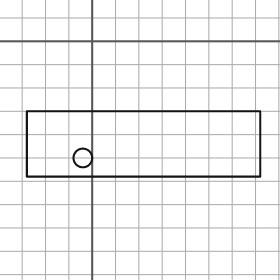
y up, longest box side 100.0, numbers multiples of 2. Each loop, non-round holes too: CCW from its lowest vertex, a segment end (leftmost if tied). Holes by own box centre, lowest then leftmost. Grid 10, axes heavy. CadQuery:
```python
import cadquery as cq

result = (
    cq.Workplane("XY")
    .moveTo(-28.0, -58.0)
    .lineTo(72.0, -58.0)
    .lineTo(72.0, -30.0)
    .lineTo(-28.0, -30.0)
    .close()
    .moveTo(-4.0, -50.0)
    .circle(4.0)
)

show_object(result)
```